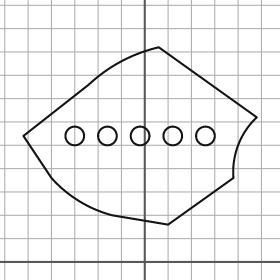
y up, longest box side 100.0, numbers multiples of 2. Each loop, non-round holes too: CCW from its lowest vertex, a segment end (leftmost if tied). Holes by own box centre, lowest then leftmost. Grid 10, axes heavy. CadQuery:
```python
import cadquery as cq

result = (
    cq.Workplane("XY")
    .moveTo(10.0, 16.0)
    .lineTo(38.0, 36.0)
    .threePointArc((40.0, 50.0), (48.0, 62.0))
    .lineTo(6.0, 92.0)
    .threePointArc((-10.0, 86.0), (-24.0, 76.0))
    .lineTo(-52.0, 54.0)
    .lineTo(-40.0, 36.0)
    .threePointArc((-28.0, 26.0), (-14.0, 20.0))
    .close()
    .moveTo(-30.0, 54.0)
    .circle(4.0)
    .moveTo(-16.0, 54.0)
    .circle(4.0)
    .moveTo(-2.0, 54.0)
    .circle(4.0)
    .moveTo(12.0, 54.0)
    .circle(4.0)
    .moveTo(26.0, 54.0)
    .circle(4.0)
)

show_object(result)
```